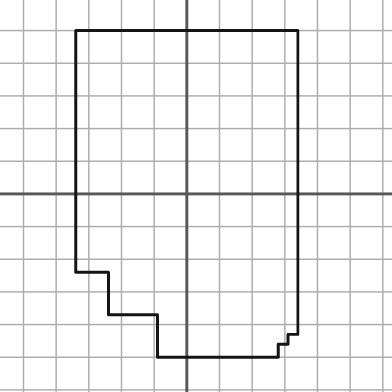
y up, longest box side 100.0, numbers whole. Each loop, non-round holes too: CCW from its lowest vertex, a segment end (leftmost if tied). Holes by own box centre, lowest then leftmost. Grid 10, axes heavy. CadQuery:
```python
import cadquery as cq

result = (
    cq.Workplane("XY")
    .moveTo(-9.0, -50.0)
    .lineTo(28.0, -50.0)
    .lineTo(28.0, -46.0)
    .lineTo(31.0, -46.0)
    .lineTo(31.0, -43.0)
    .lineTo(34.0, -43.0)
    .lineTo(34.0, 50.0)
    .lineTo(-34.0, 50.0)
    .lineTo(-34.0, -24.0)
    .lineTo(-24.0, -24.0)
    .lineTo(-24.0, -37.0)
    .lineTo(-9.0, -37.0)
    .close()
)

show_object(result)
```